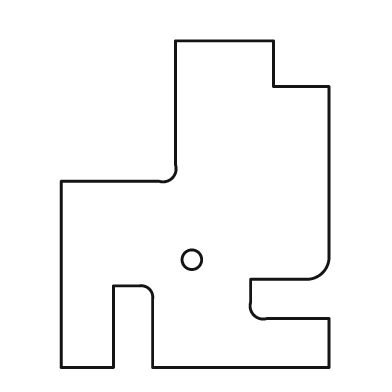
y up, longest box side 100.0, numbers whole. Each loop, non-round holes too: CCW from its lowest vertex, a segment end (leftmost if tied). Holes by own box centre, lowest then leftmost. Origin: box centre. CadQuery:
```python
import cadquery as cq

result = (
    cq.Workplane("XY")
    .moveTo(-41.0, -50.0)
    .lineTo(-25.0, -50.0)
    .lineTo(-25.0, -25.0)
    .lineTo(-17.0, -25.0)
    .threePointArc((-14.0, -26.0), (-13.0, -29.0))
    .lineTo(-13.0, -50.0)
    .lineTo(41.0, -50.0)
    .lineTo(41.0, -35.0)
    .lineTo(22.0, -35.0)
    .threePointArc((18.0, -34.0), (17.0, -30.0))
    .lineTo(17.0, -23.0)
    .lineTo(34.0, -23.0)
    .threePointArc((39.0, -21.0), (41.0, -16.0))
    .lineTo(41.0, 36.0)
    .lineTo(24.0, 36.0)
    .lineTo(24.0, 50.0)
    .lineTo(-6.0, 50.0)
    .lineTo(-6.0, 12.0)
    .threePointArc((-7.0, 8.0), (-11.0, 7.0))
    .lineTo(-41.0, 7.0)
    .close()
    .moveTo(-1.0, -17.0)
    .circle(3.0)
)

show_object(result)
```